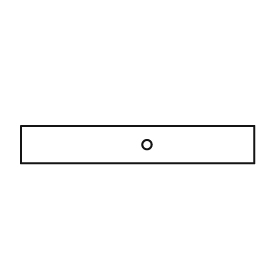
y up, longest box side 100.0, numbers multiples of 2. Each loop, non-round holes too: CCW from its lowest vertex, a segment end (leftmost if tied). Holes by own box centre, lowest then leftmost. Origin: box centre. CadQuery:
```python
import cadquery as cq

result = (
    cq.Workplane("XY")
    .moveTo(-50.0, -8.0)
    .lineTo(50.0, -8.0)
    .lineTo(50.0, 8.0)
    .lineTo(-50.0, 8.0)
    .close()
    .moveTo(4.0, 0.0)
    .circle(2.0)
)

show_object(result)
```